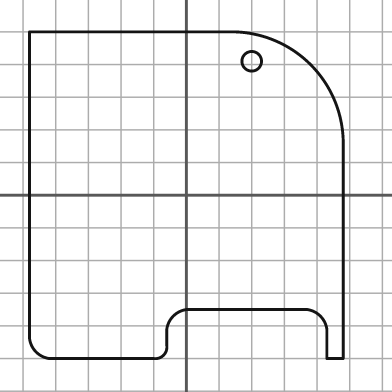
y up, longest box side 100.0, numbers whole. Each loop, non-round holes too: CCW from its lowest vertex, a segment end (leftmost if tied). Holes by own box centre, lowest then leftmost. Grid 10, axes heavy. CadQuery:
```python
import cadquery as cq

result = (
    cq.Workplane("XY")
    .moveTo(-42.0, -50.0)
    .lineTo(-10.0, -50.0)
    .threePointArc((-7.0, -49.0), (-6.0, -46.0))
    .lineTo(-6.0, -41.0)
    .threePointArc((-4.0, -37.0), (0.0, -35.0))
    .lineTo(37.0, -35.0)
    .threePointArc((41.0, -37.0), (43.0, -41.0))
    .lineTo(43.0, -50.0)
    .lineTo(48.0, -50.0)
    .lineTo(48.0, 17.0)
    .threePointArc((38.0, 40.0), (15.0, 50.0))
    .lineTo(-48.0, 50.0)
    .lineTo(-48.0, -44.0)
    .threePointArc((-46.0, -48.0), (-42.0, -50.0))
    .close()
    .moveTo(20.0, 41.0)
    .circle(3.0)
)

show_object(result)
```